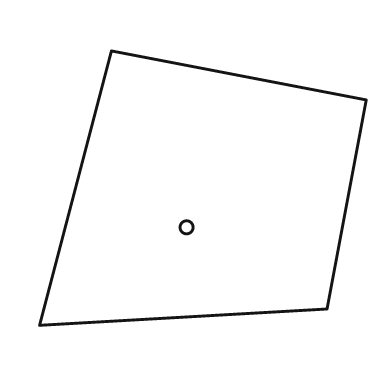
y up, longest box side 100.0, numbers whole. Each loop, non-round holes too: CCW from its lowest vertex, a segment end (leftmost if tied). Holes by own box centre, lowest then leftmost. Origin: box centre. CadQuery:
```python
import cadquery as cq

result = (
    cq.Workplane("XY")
    .moveTo(-50.0, -42.0)
    .lineTo(38.0, -37.0)
    .lineTo(50.0, 27.0)
    .lineTo(-28.0, 42.0)
    .close()
    .moveTo(-5.0, -12.0)
    .circle(2.0)
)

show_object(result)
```